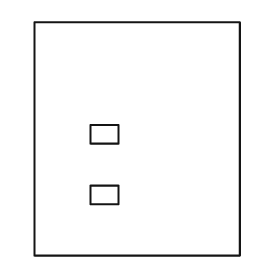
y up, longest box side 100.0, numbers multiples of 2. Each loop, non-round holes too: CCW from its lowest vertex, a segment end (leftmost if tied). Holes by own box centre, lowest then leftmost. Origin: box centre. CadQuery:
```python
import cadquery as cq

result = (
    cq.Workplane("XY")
    .moveTo(-44.0, -50.0)
    .lineTo(44.0, -50.0)
    .lineTo(44.0, 50.0)
    .lineTo(-44.0, 50.0)
    .close()
    .moveTo(-20.0, -28.0)
    .lineTo(-8.0, -28.0)
    .lineTo(-8.0, -20.0)
    .lineTo(-20.0, -20.0)
    .close()
    .moveTo(-20.0, -2.0)
    .lineTo(-8.0, -2.0)
    .lineTo(-8.0, 6.0)
    .lineTo(-20.0, 6.0)
    .close()
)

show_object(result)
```